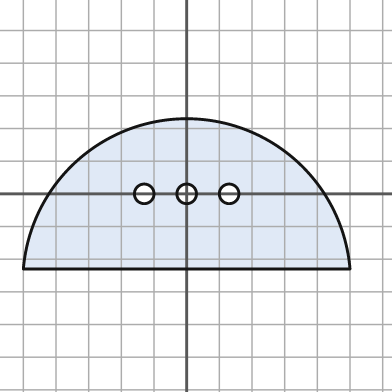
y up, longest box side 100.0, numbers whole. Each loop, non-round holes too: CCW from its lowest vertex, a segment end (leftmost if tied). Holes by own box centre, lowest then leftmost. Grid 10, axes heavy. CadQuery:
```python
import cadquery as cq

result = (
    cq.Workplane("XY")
    .moveTo(-50.0, -23.0)
    .lineTo(50.0, -23.0)
    .threePointArc((0.0, 23.0), (-50.0, -23.0))
    .close()
    .moveTo(-13.0, 0.0)
    .circle(3.0)
    .moveTo(0.0, 0.0)
    .circle(3.0)
    .moveTo(13.0, 0.0)
    .circle(3.0)
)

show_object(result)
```